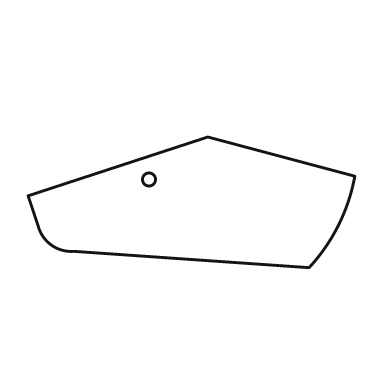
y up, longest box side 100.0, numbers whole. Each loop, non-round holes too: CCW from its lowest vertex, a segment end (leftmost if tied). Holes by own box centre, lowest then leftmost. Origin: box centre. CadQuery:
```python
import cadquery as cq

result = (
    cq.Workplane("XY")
    .moveTo(36.0, -20.0)
    .threePointArc((45.0, -7.0), (50.0, 8.0))
    .lineTo(5.0, 20.0)
    .lineTo(-50.0, 2.0)
    .lineTo(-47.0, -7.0)
    .threePointArc((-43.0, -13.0), (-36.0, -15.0))
    .close()
    .moveTo(-13.0, 7.0)
    .circle(2.0)
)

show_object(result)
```